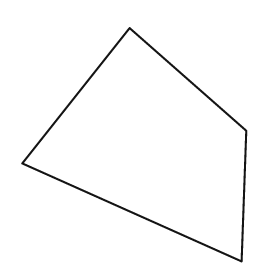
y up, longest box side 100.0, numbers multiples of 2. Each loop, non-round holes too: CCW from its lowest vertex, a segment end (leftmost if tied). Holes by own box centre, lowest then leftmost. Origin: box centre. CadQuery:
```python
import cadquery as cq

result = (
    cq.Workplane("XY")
    .moveTo(46.0, -50.0)
    .lineTo(48.0, 6.0)
    .lineTo(-2.0, 50.0)
    .lineTo(-48.0, -8.0)
    .close()
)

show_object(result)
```